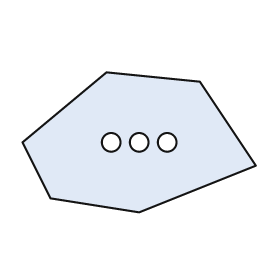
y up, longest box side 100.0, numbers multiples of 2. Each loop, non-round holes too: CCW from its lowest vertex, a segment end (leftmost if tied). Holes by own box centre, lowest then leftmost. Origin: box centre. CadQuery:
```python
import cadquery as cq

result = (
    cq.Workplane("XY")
    .moveTo(0.0, -30.0)
    .lineTo(50.0, -10.0)
    .lineTo(26.0, 26.0)
    .lineTo(-14.0, 30.0)
    .lineTo(-50.0, 0.0)
    .lineTo(-38.0, -24.0)
    .close()
    .moveTo(-12.0, 0.0)
    .circle(4.0)
    .moveTo(0.0, 0.0)
    .circle(4.0)
    .moveTo(12.0, 0.0)
    .circle(4.0)
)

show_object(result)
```